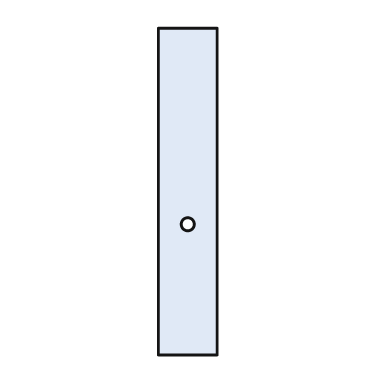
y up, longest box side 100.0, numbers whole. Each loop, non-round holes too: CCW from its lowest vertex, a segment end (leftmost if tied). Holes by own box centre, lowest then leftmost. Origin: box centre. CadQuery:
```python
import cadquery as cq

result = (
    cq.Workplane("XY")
    .moveTo(-9.0, -50.0)
    .lineTo(9.0, -50.0)
    .lineTo(9.0, 50.0)
    .lineTo(-9.0, 50.0)
    .close()
    .moveTo(0.0, -10.0)
    .circle(2.0)
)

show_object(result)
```